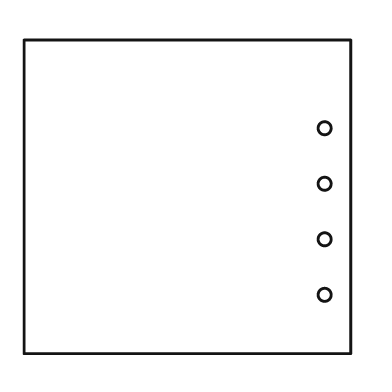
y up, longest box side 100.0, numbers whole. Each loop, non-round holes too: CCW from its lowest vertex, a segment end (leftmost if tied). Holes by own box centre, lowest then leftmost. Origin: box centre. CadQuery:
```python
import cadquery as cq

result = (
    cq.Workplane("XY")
    .moveTo(-50.0, -48.0)
    .lineTo(50.0, -48.0)
    .lineTo(50.0, 48.0)
    .lineTo(-50.0, 48.0)
    .close()
    .moveTo(42.0, -30.0)
    .circle(2.0)
    .moveTo(42.0, -13.0)
    .circle(2.0)
    .moveTo(42.0, 4.0)
    .circle(2.0)
    .moveTo(42.0, 21.0)
    .circle(2.0)
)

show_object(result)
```